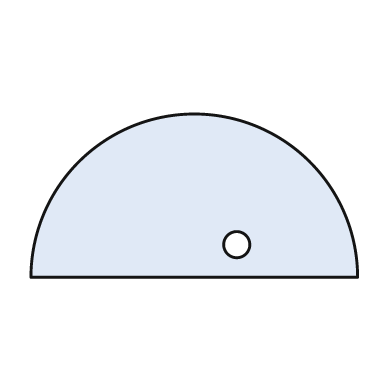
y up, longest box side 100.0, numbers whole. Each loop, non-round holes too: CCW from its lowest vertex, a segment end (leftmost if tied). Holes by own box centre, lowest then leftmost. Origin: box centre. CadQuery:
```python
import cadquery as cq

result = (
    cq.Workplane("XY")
    .moveTo(-50.0, -25.0)
    .lineTo(50.0, -25.0)
    .threePointArc((0.0, 25.0), (-50.0, -25.0))
    .close()
    .moveTo(13.0, -15.0)
    .circle(4.0)
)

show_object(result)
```